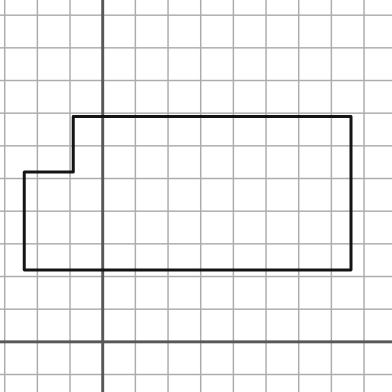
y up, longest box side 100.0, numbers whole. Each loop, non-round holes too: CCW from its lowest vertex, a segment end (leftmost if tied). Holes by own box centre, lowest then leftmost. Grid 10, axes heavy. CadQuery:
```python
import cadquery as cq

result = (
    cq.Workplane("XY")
    .moveTo(-24.0, 22.0)
    .lineTo(76.0, 22.0)
    .lineTo(76.0, 69.0)
    .lineTo(-9.0, 69.0)
    .lineTo(-9.0, 52.0)
    .lineTo(-24.0, 52.0)
    .close()
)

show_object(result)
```